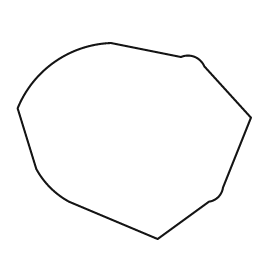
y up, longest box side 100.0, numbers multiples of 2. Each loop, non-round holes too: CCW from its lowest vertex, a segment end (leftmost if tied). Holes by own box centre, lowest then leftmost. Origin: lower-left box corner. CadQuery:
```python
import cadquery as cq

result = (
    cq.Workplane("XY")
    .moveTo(60.0, 0.0)
    .lineTo(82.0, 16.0)
    .threePointArc((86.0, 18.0), (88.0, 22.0))
    .lineTo(100.0, 52.0)
    .lineTo(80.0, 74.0)
    .threePointArc((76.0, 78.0), (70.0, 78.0))
    .lineTo(40.0, 84.0)
    .threePointArc((16.0, 76.0), (0.0, 56.0))
    .lineTo(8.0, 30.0)
    .threePointArc((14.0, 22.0), (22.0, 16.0))
    .close()
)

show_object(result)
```